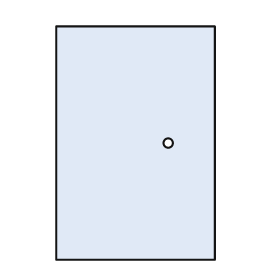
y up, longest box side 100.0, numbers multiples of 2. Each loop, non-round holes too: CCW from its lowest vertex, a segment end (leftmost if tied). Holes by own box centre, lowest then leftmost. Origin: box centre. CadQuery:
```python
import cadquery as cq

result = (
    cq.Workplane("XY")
    .moveTo(-34.0, -50.0)
    .lineTo(34.0, -50.0)
    .lineTo(34.0, 50.0)
    .lineTo(-34.0, 50.0)
    .close()
    .moveTo(14.0, 0.0)
    .circle(2.0)
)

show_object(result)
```